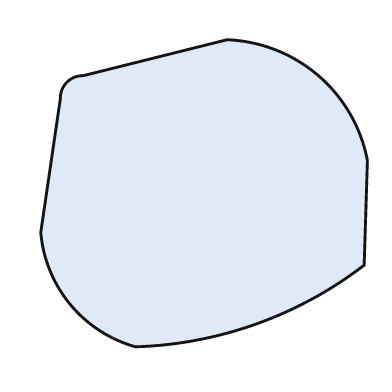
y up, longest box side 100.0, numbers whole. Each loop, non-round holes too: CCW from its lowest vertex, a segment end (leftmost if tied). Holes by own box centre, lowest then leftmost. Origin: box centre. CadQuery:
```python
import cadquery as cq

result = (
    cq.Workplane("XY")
    .moveTo(-21.0, -47.0)
    .threePointArc((16.0, -40.0), (49.0, -22.0))
    .lineTo(50.0, 10.0)
    .threePointArc((35.0, 36.0), (7.0, 47.0))
    .lineTo(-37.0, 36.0)
    .threePointArc((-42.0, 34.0), (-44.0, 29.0))
    .lineTo(-50.0, -12.0)
    .threePointArc((-41.0, -34.0), (-21.0, -47.0))
    .close()
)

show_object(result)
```